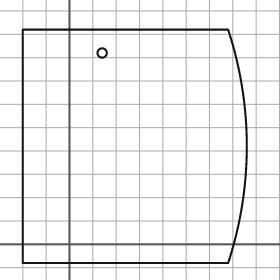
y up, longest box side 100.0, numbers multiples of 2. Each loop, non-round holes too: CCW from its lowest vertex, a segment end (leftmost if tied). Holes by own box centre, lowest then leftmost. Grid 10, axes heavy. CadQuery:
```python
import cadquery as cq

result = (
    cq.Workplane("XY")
    .moveTo(-20.0, -8.0)
    .lineTo(68.0, -8.0)
    .threePointArc((76.0, 42.0), (68.0, 92.0))
    .lineTo(-20.0, 92.0)
    .close()
    .moveTo(14.0, 82.0)
    .circle(2.0)
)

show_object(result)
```